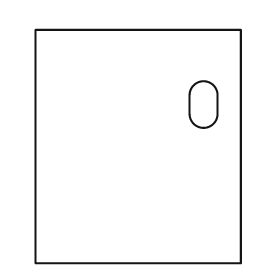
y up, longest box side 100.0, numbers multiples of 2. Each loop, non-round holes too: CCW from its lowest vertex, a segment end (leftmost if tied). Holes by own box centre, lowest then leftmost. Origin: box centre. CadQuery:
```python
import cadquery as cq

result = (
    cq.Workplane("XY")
    .moveTo(-44.0, -50.0)
    .lineTo(44.0, -50.0)
    .lineTo(44.0, 50.0)
    .lineTo(-44.0, 50.0)
    .close()
    .moveTo(22.0, 14.0)
    .threePointArc((28.0, 8.0), (34.0, 14.0))
    .lineTo(34.0, 22.0)
    .threePointArc((28.0, 28.0), (22.0, 22.0))
    .close()
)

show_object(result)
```